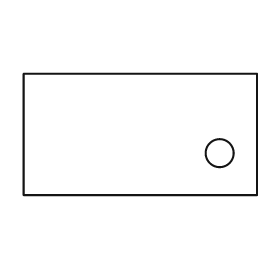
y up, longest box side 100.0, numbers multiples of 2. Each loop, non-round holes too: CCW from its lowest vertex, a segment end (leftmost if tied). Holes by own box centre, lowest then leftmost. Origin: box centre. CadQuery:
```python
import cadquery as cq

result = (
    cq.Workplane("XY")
    .moveTo(-50.0, -26.0)
    .lineTo(50.0, -26.0)
    .lineTo(50.0, 26.0)
    .lineTo(-50.0, 26.0)
    .close()
    .moveTo(34.0, -8.0)
    .circle(6.0)
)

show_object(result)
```